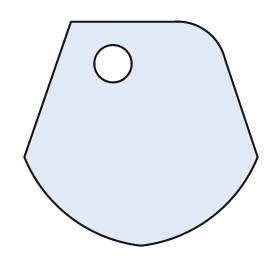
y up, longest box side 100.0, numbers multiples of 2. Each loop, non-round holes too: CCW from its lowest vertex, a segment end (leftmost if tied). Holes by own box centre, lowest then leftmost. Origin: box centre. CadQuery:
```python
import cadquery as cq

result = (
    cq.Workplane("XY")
    .moveTo(0.0, -48.0)
    .threePointArc((30.0, -36.0), (50.0, -10.0))
    .lineTo(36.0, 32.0)
    .threePointArc((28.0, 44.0), (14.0, 48.0))
    .lineTo(-30.0, 48.0)
    .lineTo(-50.0, -10.0)
    .threePointArc((-30.0, -36.0), (0.0, -48.0))
    .close()
    .moveTo(-12.0, 30.0)
    .circle(8.0)
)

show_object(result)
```